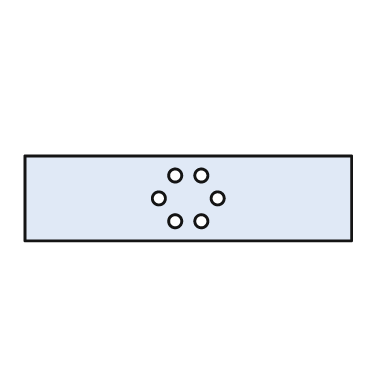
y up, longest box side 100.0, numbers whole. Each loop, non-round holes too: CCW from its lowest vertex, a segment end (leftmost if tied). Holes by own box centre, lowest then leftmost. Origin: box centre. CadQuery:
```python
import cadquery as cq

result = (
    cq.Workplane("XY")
    .moveTo(-50.0, -13.0)
    .lineTo(50.0, -13.0)
    .lineTo(50.0, 13.0)
    .lineTo(-50.0, 13.0)
    .close()
    .moveTo(-4.0, -7.0)
    .circle(2.0)
    .moveTo(4.0, -7.0)
    .circle(2.0)
    .moveTo(-9.0, 0.0)
    .circle(2.0)
    .moveTo(9.0, 0.0)
    .circle(2.0)
    .moveTo(-4.0, 7.0)
    .circle(2.0)
    .moveTo(4.0, 7.0)
    .circle(2.0)
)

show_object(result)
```